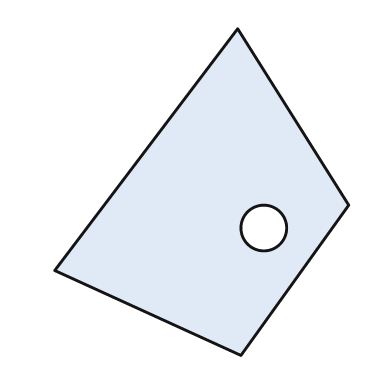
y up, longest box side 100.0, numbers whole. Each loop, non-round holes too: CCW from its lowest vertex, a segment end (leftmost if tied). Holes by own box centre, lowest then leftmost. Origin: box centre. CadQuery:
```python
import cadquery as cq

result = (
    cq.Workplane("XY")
    .moveTo(12.0, -50.0)
    .lineTo(45.0, -4.0)
    .lineTo(11.0, 50.0)
    .lineTo(-45.0, -24.0)
    .close()
    .moveTo(19.0, -11.0)
    .circle(7.0)
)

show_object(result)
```